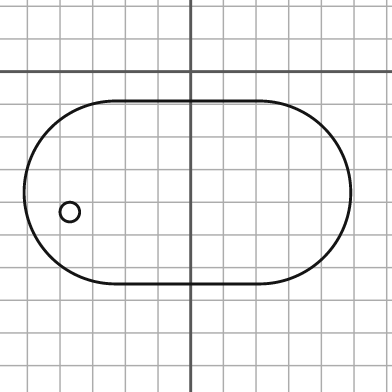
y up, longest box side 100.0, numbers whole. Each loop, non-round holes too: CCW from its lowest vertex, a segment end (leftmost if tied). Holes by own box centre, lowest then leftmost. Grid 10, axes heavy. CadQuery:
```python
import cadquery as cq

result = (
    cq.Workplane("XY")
    .moveTo(-23.0, -65.0)
    .lineTo(21.0, -65.0)
    .threePointArc((49.0, -37.0), (21.0, -9.0))
    .lineTo(-23.0, -9.0)
    .threePointArc((-51.0, -37.0), (-23.0, -65.0))
    .close()
    .moveTo(-37.0, -43.0)
    .circle(3.0)
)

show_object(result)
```